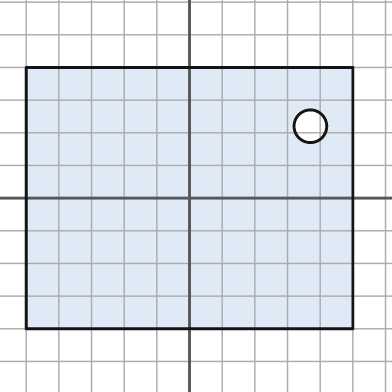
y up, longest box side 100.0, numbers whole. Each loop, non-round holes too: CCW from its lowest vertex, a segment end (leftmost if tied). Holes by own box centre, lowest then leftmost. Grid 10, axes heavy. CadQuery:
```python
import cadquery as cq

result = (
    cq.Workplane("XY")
    .moveTo(-50.0, -40.0)
    .lineTo(50.0, -40.0)
    .lineTo(50.0, 40.0)
    .lineTo(-50.0, 40.0)
    .close()
    .moveTo(37.0, 22.0)
    .circle(5.0)
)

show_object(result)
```